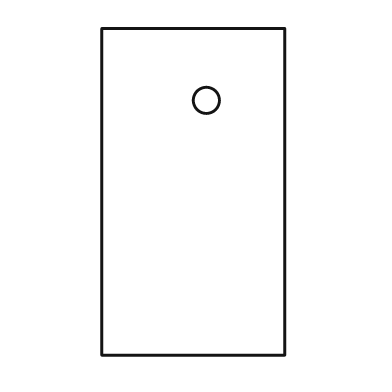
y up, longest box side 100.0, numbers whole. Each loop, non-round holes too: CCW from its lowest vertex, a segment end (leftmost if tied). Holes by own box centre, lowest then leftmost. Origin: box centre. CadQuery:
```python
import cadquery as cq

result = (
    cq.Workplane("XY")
    .moveTo(-28.0, -50.0)
    .lineTo(28.0, -50.0)
    .lineTo(28.0, 50.0)
    .lineTo(-28.0, 50.0)
    .close()
    .moveTo(4.0, 28.0)
    .circle(4.0)
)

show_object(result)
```